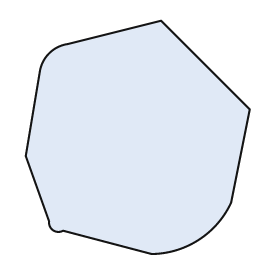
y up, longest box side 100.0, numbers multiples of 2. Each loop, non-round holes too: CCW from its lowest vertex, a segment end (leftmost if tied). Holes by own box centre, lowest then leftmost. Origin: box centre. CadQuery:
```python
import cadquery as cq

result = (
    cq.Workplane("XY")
    .moveTo(6.0, -50.0)
    .threePointArc((26.0, -44.0), (40.0, -28.0))
    .lineTo(48.0, 12.0)
    .lineTo(10.0, 50.0)
    .lineTo(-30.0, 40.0)
    .threePointArc((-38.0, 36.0), (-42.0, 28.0))
    .lineTo(-48.0, -8.0)
    .lineTo(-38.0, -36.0)
    .threePointArc((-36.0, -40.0), (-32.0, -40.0))
    .close()
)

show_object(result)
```